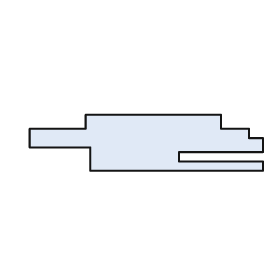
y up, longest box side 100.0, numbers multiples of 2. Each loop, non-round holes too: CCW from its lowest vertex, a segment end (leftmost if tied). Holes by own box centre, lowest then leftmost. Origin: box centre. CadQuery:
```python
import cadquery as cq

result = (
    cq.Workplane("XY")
    .moveTo(-24.0, -12.0)
    .lineTo(50.0, -12.0)
    .lineTo(50.0, -8.0)
    .lineTo(14.0, -8.0)
    .lineTo(14.0, -4.0)
    .lineTo(50.0, -4.0)
    .lineTo(50.0, 2.0)
    .lineTo(44.0, 2.0)
    .lineTo(44.0, 6.0)
    .lineTo(32.0, 6.0)
    .lineTo(32.0, 12.0)
    .lineTo(-26.0, 12.0)
    .lineTo(-26.0, 6.0)
    .lineTo(-50.0, 6.0)
    .lineTo(-50.0, -2.0)
    .lineTo(-24.0, -2.0)
    .close()
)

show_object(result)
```